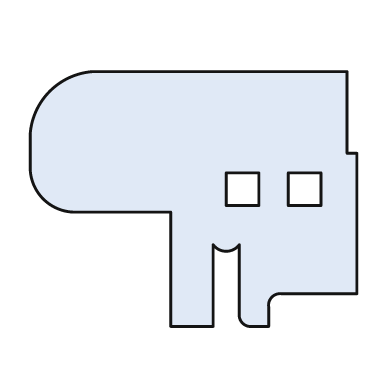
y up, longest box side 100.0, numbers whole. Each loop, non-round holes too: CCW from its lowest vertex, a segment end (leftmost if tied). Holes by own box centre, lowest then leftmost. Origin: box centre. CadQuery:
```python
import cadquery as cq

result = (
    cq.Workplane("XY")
    .moveTo(-7.0, -39.0)
    .lineTo(6.0, -39.0)
    .lineTo(6.0, -14.0)
    .threePointArc((10.0, -16.0), (14.0, -14.0))
    .lineTo(14.0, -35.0)
    .threePointArc((15.0, -38.0), (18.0, -39.0))
    .lineTo(23.0, -39.0)
    .lineTo(23.0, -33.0)
    .threePointArc((24.0, -30.0), (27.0, -29.0))
    .lineTo(50.0, -29.0)
    .lineTo(50.0, 14.0)
    .lineTo(47.0, 14.0)
    .lineTo(47.0, 39.0)
    .lineTo(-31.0, 39.0)
    .threePointArc((-44.0, 33.0), (-50.0, 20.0))
    .lineTo(-50.0, 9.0)
    .threePointArc((-46.0, 0.0), (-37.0, -4.0))
    .lineTo(-7.0, -4.0)
    .close()
    .moveTo(10.0, -2.0)
    .lineTo(20.0, -2.0)
    .lineTo(20.0, 8.0)
    .lineTo(10.0, 8.0)
    .close()
    .moveTo(29.0, -2.0)
    .lineTo(39.0, -2.0)
    .lineTo(39.0, 8.0)
    .lineTo(29.0, 8.0)
    .close()
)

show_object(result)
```